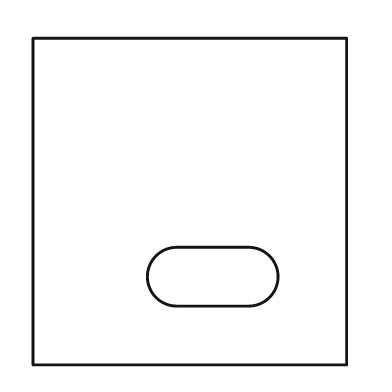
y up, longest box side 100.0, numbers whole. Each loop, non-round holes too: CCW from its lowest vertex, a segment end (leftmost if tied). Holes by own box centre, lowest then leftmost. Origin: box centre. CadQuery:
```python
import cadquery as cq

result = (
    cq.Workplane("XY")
    .moveTo(-48.0, -50.0)
    .lineTo(48.0, -50.0)
    .lineTo(48.0, 50.0)
    .lineTo(-48.0, 50.0)
    .close()
    .moveTo(-4.0, -32.0)
    .lineTo(18.0, -32.0)
    .threePointArc((27.0, -23.0), (18.0, -14.0))
    .lineTo(-4.0, -14.0)
    .threePointArc((-13.0, -23.0), (-4.0, -32.0))
    .close()
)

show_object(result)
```